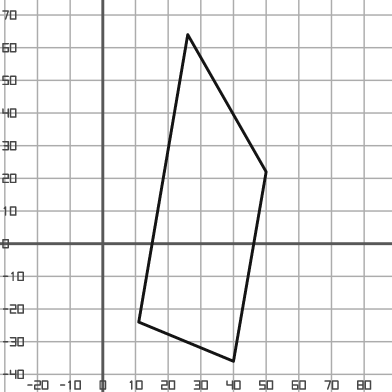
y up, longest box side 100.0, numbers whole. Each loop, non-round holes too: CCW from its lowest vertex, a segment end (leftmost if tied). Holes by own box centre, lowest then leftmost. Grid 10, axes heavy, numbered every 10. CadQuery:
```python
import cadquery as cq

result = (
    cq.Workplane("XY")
    .moveTo(40.0, -36.0)
    .lineTo(50.0, 22.0)
    .lineTo(26.0, 64.0)
    .lineTo(11.0, -24.0)
    .close()
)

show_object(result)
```